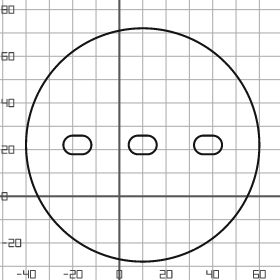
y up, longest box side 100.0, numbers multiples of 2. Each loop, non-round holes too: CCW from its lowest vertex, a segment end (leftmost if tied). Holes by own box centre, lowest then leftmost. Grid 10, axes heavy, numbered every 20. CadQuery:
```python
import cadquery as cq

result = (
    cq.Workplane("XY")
    .moveTo(10.0, 22.0)
    .circle(50.0)
    .moveTo(-20.0, 18.0)
    .lineTo(-16.0, 18.0)
    .threePointArc((-12.0, 22.0), (-16.0, 26.0))
    .lineTo(-20.0, 26.0)
    .threePointArc((-24.0, 22.0), (-20.0, 18.0))
    .close()
    .moveTo(8.0, 18.0)
    .lineTo(12.0, 18.0)
    .threePointArc((16.0, 22.0), (12.0, 26.0))
    .lineTo(8.0, 26.0)
    .threePointArc((4.0, 22.0), (8.0, 18.0))
    .close()
    .moveTo(36.0, 18.0)
    .lineTo(40.0, 18.0)
    .threePointArc((44.0, 22.0), (40.0, 26.0))
    .lineTo(36.0, 26.0)
    .threePointArc((32.0, 22.0), (36.0, 18.0))
    .close()
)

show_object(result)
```